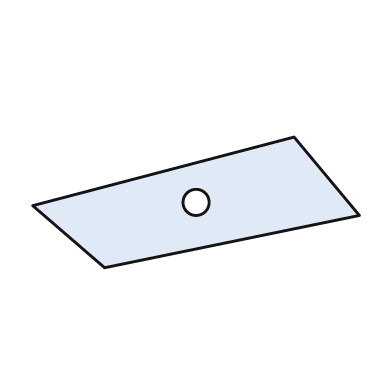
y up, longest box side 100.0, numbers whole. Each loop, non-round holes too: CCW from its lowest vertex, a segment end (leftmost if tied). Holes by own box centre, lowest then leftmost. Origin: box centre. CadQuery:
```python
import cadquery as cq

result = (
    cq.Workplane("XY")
    .moveTo(-28.0, -20.0)
    .lineTo(50.0, -4.0)
    .lineTo(30.0, 20.0)
    .lineTo(-50.0, -1.0)
    .close()
    .moveTo(0.0, 0.0)
    .circle(4.0)
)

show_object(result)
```